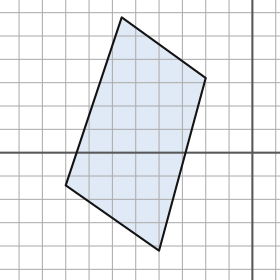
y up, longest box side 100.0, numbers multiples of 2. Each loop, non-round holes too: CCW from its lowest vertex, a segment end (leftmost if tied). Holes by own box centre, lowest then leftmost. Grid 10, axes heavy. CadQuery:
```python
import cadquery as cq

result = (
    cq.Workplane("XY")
    .moveTo(-40.0, -42.0)
    .lineTo(-20.0, 32.0)
    .lineTo(-56.0, 58.0)
    .lineTo(-80.0, -14.0)
    .close()
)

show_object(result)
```